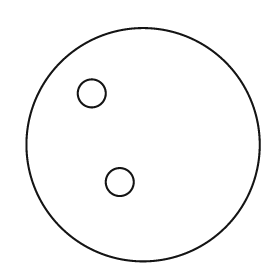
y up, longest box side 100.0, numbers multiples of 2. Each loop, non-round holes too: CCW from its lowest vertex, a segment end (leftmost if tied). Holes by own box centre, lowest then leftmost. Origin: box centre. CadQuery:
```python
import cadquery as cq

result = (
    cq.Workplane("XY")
    .moveTo(0.0, 0.0)
    .circle(50.0)
    .moveTo(-10.0, -16.0)
    .circle(6.0)
    .moveTo(-22.0, 22.0)
    .circle(6.0)
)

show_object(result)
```